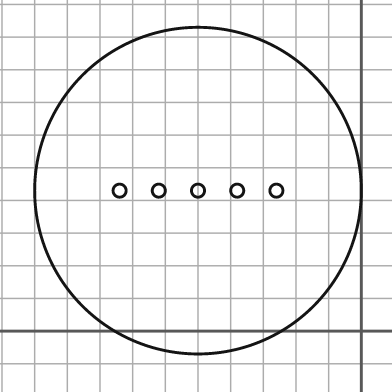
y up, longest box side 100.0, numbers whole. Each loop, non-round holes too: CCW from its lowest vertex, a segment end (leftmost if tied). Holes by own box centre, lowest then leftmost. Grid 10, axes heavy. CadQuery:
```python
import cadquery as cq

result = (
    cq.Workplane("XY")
    .moveTo(-50.0, 43.0)
    .circle(50.0)
    .moveTo(-74.0, 43.0)
    .circle(2.0)
    .moveTo(-62.0, 43.0)
    .circle(2.0)
    .moveTo(-50.0, 43.0)
    .circle(2.0)
    .moveTo(-38.0, 43.0)
    .circle(2.0)
    .moveTo(-26.0, 43.0)
    .circle(2.0)
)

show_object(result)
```